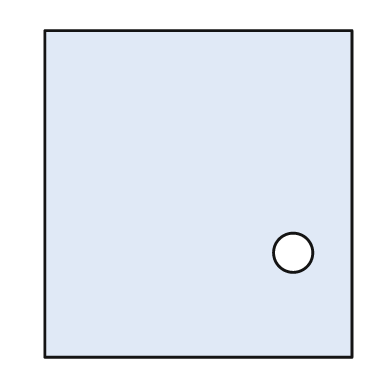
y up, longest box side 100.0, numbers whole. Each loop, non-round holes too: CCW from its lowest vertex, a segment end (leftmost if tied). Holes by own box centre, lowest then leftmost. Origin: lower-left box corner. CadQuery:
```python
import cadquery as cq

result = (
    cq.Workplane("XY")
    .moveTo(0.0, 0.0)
    .lineTo(94.0, 0.0)
    .lineTo(94.0, 100.0)
    .lineTo(0.0, 100.0)
    .close()
    .moveTo(76.0, 32.0)
    .circle(6.0)
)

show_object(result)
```